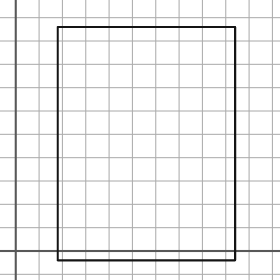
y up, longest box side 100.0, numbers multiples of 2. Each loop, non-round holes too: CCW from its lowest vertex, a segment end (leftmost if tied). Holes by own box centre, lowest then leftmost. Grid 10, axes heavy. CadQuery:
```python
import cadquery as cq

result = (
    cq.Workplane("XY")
    .moveTo(18.0, -4.0)
    .lineTo(94.0, -4.0)
    .lineTo(94.0, 96.0)
    .lineTo(18.0, 96.0)
    .close()
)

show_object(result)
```